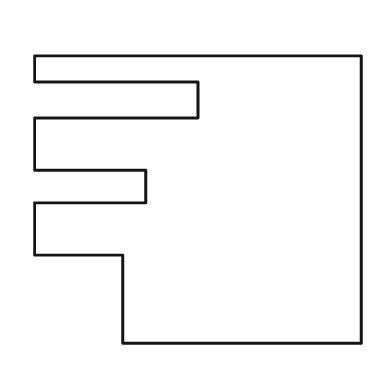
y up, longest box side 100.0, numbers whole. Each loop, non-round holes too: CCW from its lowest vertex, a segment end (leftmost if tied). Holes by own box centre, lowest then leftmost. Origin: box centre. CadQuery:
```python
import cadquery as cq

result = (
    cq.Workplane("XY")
    .moveTo(-23.0, -44.0)
    .lineTo(50.0, -44.0)
    .lineTo(50.0, 44.0)
    .lineTo(-50.0, 44.0)
    .lineTo(-50.0, 36.0)
    .lineTo(0.0, 36.0)
    .lineTo(0.0, 25.0)
    .lineTo(-50.0, 25.0)
    .lineTo(-50.0, 9.0)
    .lineTo(-16.0, 9.0)
    .lineTo(-16.0, -1.0)
    .lineTo(-50.0, -1.0)
    .lineTo(-50.0, -17.0)
    .lineTo(-23.0, -17.0)
    .close()
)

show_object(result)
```